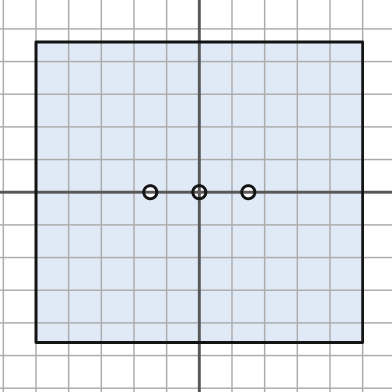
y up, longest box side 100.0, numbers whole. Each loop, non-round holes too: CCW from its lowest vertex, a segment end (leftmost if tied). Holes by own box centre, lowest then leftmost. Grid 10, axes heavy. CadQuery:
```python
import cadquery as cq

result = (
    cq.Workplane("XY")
    .moveTo(-50.0, -46.0)
    .lineTo(50.0, -46.0)
    .lineTo(50.0, 46.0)
    .lineTo(-50.0, 46.0)
    .close()
    .moveTo(-15.0, 0.0)
    .circle(2.0)
    .moveTo(0.0, 0.0)
    .circle(2.0)
    .moveTo(15.0, 0.0)
    .circle(2.0)
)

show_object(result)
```